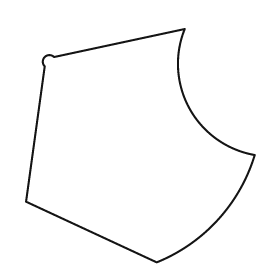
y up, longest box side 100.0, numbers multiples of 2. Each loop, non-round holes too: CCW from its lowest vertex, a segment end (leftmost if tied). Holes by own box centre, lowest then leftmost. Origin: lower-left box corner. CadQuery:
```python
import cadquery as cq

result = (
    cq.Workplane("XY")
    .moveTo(56.0, 0.0)
    .threePointArc((82.0, 18.0), (98.0, 46.0))
    .threePointArc((70.0, 66.0), (68.0, 100.0))
    .lineTo(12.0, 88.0)
    .threePointArc((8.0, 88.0), (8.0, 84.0))
    .lineTo(0.0, 26.0)
    .close()
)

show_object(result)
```